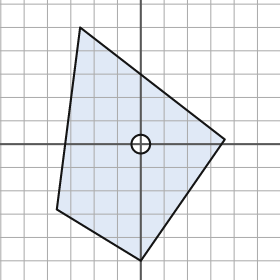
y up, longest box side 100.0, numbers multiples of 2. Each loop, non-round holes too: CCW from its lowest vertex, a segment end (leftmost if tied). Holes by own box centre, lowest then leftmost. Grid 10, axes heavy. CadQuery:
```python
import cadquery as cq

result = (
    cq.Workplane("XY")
    .moveTo(0.0, -50.0)
    .lineTo(36.0, 2.0)
    .lineTo(-26.0, 50.0)
    .lineTo(-36.0, -28.0)
    .close()
    .moveTo(0.0, 0.0)
    .circle(4.0)
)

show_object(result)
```